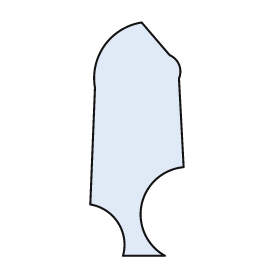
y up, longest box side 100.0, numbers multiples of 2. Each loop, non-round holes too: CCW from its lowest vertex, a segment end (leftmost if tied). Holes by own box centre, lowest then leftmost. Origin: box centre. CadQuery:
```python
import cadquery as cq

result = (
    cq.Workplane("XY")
    .moveTo(-6.0, -50.0)
    .lineTo(12.0, -50.0)
    .threePointArc((2.0, -28.0), (20.0, -12.0))
    .lineTo(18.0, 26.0)
    .threePointArc((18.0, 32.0), (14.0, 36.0))
    .lineTo(2.0, 50.0)
    .threePointArc((-14.0, 40.0), (-18.0, 22.0))
    .lineTo(-20.0, -28.0)
    .threePointArc((-8.0, -36.0), (-6.0, -50.0))
    .close()
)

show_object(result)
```